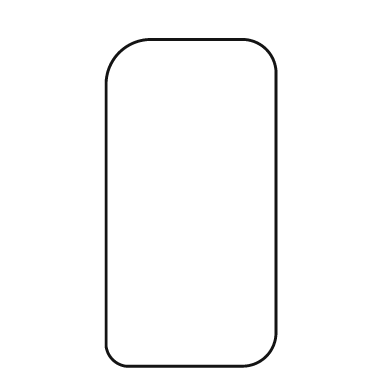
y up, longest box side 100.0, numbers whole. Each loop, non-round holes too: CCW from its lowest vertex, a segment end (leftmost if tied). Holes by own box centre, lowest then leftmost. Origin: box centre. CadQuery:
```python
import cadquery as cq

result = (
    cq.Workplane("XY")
    .moveTo(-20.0, -50.0)
    .lineTo(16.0, -50.0)
    .threePointArc((23.0, -47.0), (26.0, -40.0))
    .lineTo(26.0, 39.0)
    .threePointArc((23.0, 47.0), (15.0, 50.0))
    .lineTo(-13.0, 50.0)
    .threePointArc((-22.0, 46.0), (-26.0, 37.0))
    .lineTo(-26.0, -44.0)
    .threePointArc((-24.0, -48.0), (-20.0, -50.0))
    .close()
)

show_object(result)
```